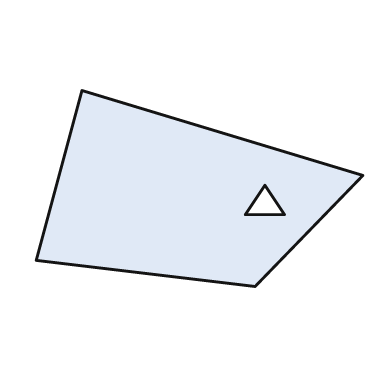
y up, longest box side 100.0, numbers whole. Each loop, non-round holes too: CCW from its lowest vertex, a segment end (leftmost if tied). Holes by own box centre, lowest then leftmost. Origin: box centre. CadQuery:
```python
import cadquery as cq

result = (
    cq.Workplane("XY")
    .moveTo(17.0, -30.0)
    .lineTo(50.0, 4.0)
    .lineTo(-36.0, 30.0)
    .lineTo(-50.0, -22.0)
    .close()
    .moveTo(14.0, -8.0)
    .lineTo(26.0, -8.0)
    .lineTo(20.0, 1.0)
    .close()
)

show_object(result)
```